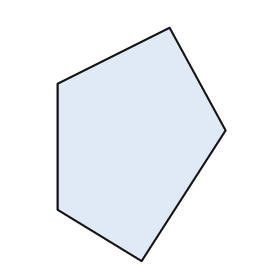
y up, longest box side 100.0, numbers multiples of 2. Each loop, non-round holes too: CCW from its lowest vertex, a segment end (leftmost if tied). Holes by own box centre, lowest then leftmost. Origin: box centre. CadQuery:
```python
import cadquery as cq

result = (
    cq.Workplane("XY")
    .moveTo(0.0, -50.0)
    .lineTo(36.0, 6.0)
    .lineTo(12.0, 50.0)
    .lineTo(-36.0, 26.0)
    .lineTo(-36.0, -28.0)
    .close()
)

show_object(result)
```